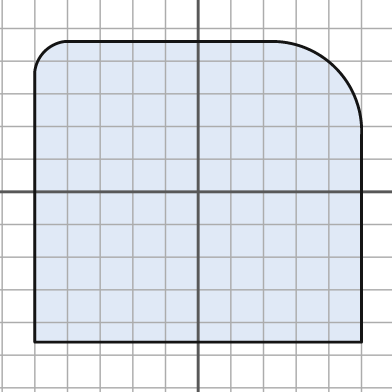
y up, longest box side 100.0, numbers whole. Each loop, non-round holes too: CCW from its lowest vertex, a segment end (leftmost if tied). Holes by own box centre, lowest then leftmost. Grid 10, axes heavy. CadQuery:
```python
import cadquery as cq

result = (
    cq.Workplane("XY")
    .moveTo(-50.0, -46.0)
    .lineTo(50.0, -46.0)
    .lineTo(50.0, 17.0)
    .threePointArc((42.0, 38.0), (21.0, 46.0))
    .lineTo(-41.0, 46.0)
    .threePointArc((-47.0, 43.0), (-50.0, 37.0))
    .close()
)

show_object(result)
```